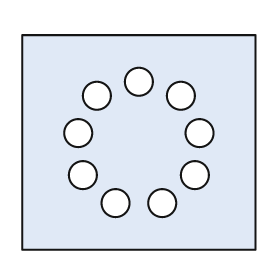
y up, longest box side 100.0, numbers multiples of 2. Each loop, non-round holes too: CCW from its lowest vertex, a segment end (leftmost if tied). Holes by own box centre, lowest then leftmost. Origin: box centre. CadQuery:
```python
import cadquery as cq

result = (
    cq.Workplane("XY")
    .moveTo(-50.0, -46.0)
    .lineTo(50.0, -46.0)
    .lineTo(50.0, 46.0)
    .lineTo(-50.0, 46.0)
    .close()
    .moveTo(-10.0, -26.0)
    .circle(6.0)
    .moveTo(10.0, -26.0)
    .circle(6.0)
    .moveTo(-24.0, -14.0)
    .circle(6.0)
    .moveTo(24.0, -14.0)
    .circle(6.0)
    .moveTo(-26.0, 4.0)
    .circle(6.0)
    .moveTo(26.0, 4.0)
    .circle(6.0)
    .moveTo(-18.0, 20.0)
    .circle(6.0)
    .moveTo(18.0, 20.0)
    .circle(6.0)
    .moveTo(0.0, 26.0)
    .circle(6.0)
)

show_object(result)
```